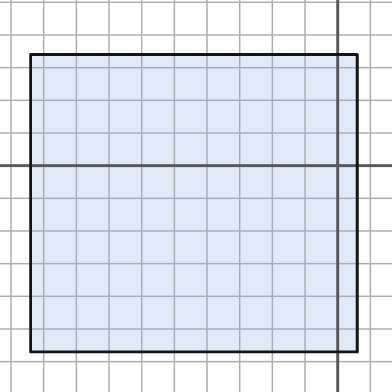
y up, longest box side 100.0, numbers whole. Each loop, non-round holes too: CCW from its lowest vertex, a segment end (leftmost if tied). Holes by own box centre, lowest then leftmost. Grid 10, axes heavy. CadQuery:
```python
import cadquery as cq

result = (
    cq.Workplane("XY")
    .moveTo(-94.0, -57.0)
    .lineTo(6.0, -57.0)
    .lineTo(6.0, 34.0)
    .lineTo(-94.0, 34.0)
    .close()
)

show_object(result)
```